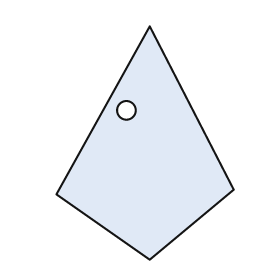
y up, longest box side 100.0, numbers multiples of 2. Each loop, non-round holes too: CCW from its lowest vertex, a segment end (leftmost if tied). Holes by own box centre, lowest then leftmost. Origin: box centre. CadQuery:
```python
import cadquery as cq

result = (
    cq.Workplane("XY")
    .moveTo(2.0, -50.0)
    .lineTo(38.0, -20.0)
    .lineTo(2.0, 50.0)
    .lineTo(-38.0, -22.0)
    .close()
    .moveTo(-8.0, 14.0)
    .circle(4.0)
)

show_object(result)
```